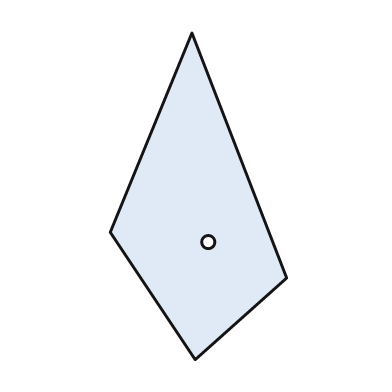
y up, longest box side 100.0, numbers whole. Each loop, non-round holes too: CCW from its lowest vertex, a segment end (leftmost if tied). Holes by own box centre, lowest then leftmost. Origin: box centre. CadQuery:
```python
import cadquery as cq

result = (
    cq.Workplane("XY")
    .moveTo(-1.0, -50.0)
    .lineTo(27.0, -25.0)
    .lineTo(-2.0, 50.0)
    .lineTo(-27.0, -11.0)
    .close()
    .moveTo(3.0, -14.0)
    .circle(2.0)
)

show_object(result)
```